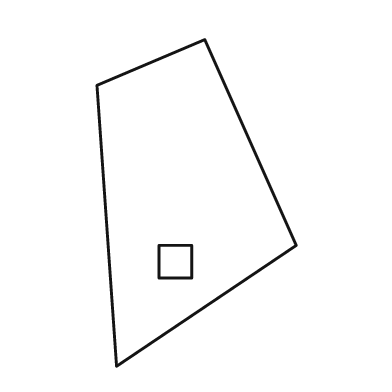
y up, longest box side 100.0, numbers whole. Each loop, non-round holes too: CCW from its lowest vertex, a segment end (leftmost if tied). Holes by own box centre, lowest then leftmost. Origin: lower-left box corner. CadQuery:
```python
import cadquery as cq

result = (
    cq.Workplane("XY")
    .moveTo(6.0, 0.0)
    .lineTo(61.0, 37.0)
    .lineTo(33.0, 100.0)
    .lineTo(0.0, 86.0)
    .close()
    .moveTo(19.0, 27.0)
    .lineTo(29.0, 27.0)
    .lineTo(29.0, 37.0)
    .lineTo(19.0, 37.0)
    .close()
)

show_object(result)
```